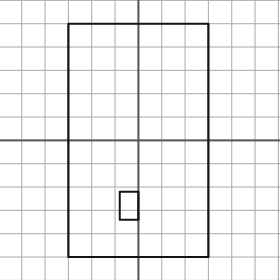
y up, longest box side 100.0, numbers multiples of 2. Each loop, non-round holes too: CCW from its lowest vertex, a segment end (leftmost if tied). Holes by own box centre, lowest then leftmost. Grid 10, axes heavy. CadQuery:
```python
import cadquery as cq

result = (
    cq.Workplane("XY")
    .moveTo(-30.0, -50.0)
    .lineTo(30.0, -50.0)
    .lineTo(30.0, 50.0)
    .lineTo(-30.0, 50.0)
    .close()
    .moveTo(-8.0, -34.0)
    .lineTo(0.0, -34.0)
    .lineTo(0.0, -22.0)
    .lineTo(-8.0, -22.0)
    .close()
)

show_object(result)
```